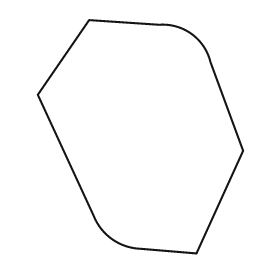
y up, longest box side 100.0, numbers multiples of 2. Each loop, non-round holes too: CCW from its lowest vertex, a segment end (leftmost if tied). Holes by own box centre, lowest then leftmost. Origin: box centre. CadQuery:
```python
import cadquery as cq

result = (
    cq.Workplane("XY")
    .moveTo(24.0, -50.0)
    .lineTo(44.0, -6.0)
    .lineTo(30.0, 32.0)
    .threePointArc((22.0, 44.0), (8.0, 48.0))
    .lineTo(-22.0, 50.0)
    .lineTo(-44.0, 18.0)
    .lineTo(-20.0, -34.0)
    .threePointArc((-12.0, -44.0), (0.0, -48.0))
    .close()
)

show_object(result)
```